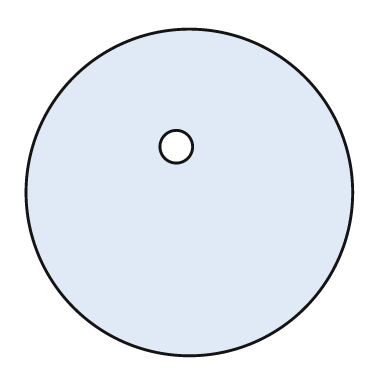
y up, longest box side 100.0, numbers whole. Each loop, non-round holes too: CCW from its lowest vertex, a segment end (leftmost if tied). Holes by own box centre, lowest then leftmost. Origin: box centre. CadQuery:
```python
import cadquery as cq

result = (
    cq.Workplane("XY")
    .moveTo(0.0, 0.0)
    .circle(50.0)
    .moveTo(-4.0, 14.0)
    .circle(5.0)
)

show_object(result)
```